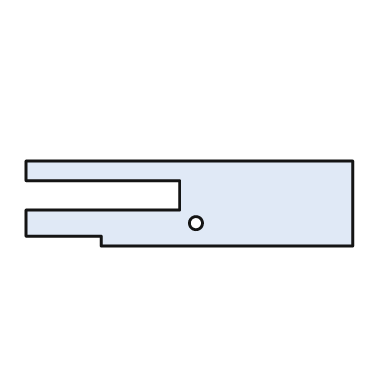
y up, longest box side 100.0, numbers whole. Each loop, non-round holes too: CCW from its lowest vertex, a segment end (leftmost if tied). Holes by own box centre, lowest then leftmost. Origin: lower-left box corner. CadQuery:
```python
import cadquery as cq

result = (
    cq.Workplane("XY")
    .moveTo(23.0, 0.0)
    .lineTo(100.0, 0.0)
    .lineTo(100.0, 26.0)
    .lineTo(0.0, 26.0)
    .lineTo(0.0, 20.0)
    .lineTo(47.0, 20.0)
    .lineTo(47.0, 11.0)
    .lineTo(0.0, 11.0)
    .lineTo(0.0, 3.0)
    .lineTo(23.0, 3.0)
    .close()
    .moveTo(52.0, 7.0)
    .circle(2.0)
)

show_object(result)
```